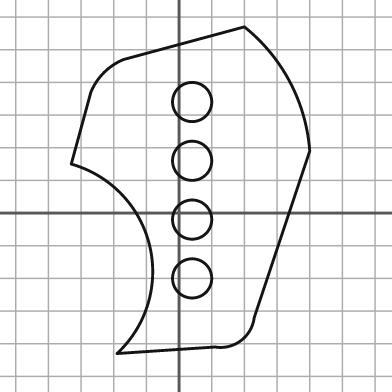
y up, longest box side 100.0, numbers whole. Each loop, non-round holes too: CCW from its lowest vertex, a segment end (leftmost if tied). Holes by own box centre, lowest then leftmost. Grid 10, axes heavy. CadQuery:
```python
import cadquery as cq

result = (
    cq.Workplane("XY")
    .moveTo(-19.0, -43.0)
    .lineTo(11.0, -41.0)
    .threePointArc((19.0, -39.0), (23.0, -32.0))
    .lineTo(40.0, 19.0)
    .threePointArc((34.0, 40.0), (20.0, 57.0))
    .lineTo(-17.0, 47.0)
    .threePointArc((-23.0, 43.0), (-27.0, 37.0))
    .lineTo(-33.0, 15.0)
    .threePointArc((-9.0, -10.0), (-19.0, -43.0))
    .close()
    .moveTo(4.0, -20.0)
    .circle(6.0)
    .moveTo(4.0, -2.0)
    .circle(6.0)
    .moveTo(4.0, 16.0)
    .circle(6.0)
    .moveTo(4.0, 34.0)
    .circle(6.0)
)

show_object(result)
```